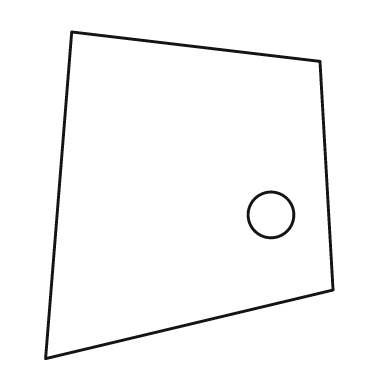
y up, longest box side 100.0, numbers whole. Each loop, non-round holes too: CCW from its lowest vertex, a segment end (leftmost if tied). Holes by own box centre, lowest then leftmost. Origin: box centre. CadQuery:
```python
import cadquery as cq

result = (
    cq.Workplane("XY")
    .moveTo(-44.0, -50.0)
    .lineTo(44.0, -29.0)
    .lineTo(40.0, 41.0)
    .lineTo(-36.0, 50.0)
    .close()
    .moveTo(25.0, -6.0)
    .circle(7.0)
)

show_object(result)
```